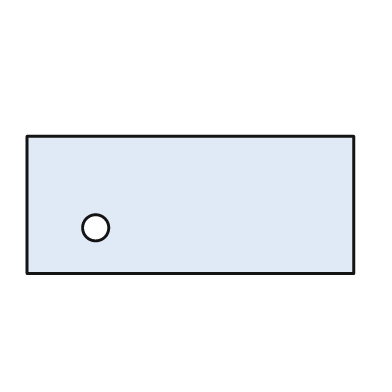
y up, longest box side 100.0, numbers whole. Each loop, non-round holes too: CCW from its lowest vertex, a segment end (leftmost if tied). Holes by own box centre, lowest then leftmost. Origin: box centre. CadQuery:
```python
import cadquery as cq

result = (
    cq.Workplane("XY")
    .moveTo(-50.0, -21.0)
    .lineTo(50.0, -21.0)
    .lineTo(50.0, 21.0)
    .lineTo(-50.0, 21.0)
    .close()
    .moveTo(-29.0, -7.0)
    .circle(4.0)
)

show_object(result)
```